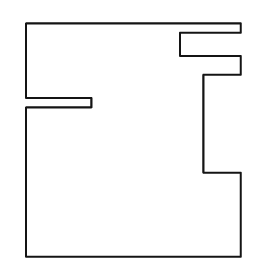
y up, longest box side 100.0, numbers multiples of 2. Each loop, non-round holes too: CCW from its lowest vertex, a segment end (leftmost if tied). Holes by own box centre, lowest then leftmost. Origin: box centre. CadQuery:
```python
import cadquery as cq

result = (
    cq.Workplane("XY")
    .moveTo(-46.0, -50.0)
    .lineTo(46.0, -50.0)
    .lineTo(46.0, -14.0)
    .lineTo(30.0, -14.0)
    .lineTo(30.0, 28.0)
    .lineTo(46.0, 28.0)
    .lineTo(46.0, 36.0)
    .lineTo(20.0, 36.0)
    .lineTo(20.0, 46.0)
    .lineTo(46.0, 46.0)
    .lineTo(46.0, 50.0)
    .lineTo(-46.0, 50.0)
    .lineTo(-46.0, 18.0)
    .lineTo(-18.0, 18.0)
    .lineTo(-18.0, 14.0)
    .lineTo(-46.0, 14.0)
    .close()
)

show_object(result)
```